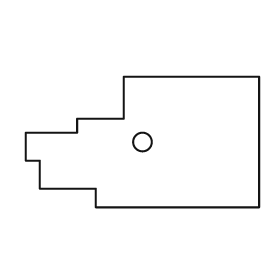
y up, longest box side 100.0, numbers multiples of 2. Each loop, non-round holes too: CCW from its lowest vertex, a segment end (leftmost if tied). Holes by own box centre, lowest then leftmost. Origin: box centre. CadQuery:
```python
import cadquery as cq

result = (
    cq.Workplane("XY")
    .moveTo(-20.0, -28.0)
    .lineTo(50.0, -28.0)
    .lineTo(50.0, 28.0)
    .lineTo(-8.0, 28.0)
    .lineTo(-8.0, 10.0)
    .lineTo(-28.0, 10.0)
    .lineTo(-28.0, 4.0)
    .lineTo(-50.0, 4.0)
    .lineTo(-50.0, -8.0)
    .lineTo(-44.0, -8.0)
    .lineTo(-44.0, -20.0)
    .lineTo(-20.0, -20.0)
    .close()
    .moveTo(0.0, 0.0)
    .circle(4.0)
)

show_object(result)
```